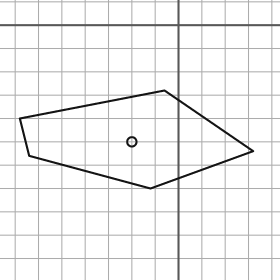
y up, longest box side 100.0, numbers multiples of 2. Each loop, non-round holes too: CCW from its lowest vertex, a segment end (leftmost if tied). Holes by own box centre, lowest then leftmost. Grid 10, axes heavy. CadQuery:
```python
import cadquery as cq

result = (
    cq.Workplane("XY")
    .moveTo(-12.0, -70.0)
    .lineTo(32.0, -54.0)
    .lineTo(-6.0, -28.0)
    .lineTo(-68.0, -40.0)
    .lineTo(-64.0, -56.0)
    .close()
    .moveTo(-20.0, -50.0)
    .circle(2.0)
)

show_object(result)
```